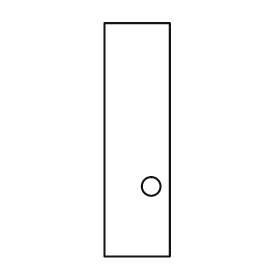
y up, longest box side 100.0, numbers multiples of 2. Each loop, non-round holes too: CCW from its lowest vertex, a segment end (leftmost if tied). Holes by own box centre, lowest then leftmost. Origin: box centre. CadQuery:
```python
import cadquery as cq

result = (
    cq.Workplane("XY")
    .moveTo(-14.0, -50.0)
    .lineTo(14.0, -50.0)
    .lineTo(14.0, 50.0)
    .lineTo(-14.0, 50.0)
    .close()
    .moveTo(6.0, -20.0)
    .circle(4.0)
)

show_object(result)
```